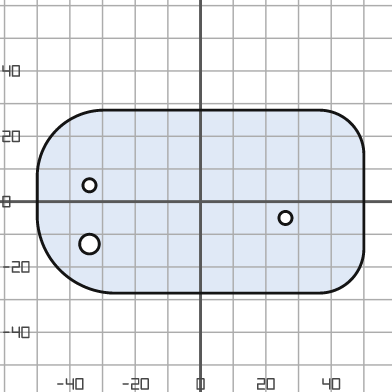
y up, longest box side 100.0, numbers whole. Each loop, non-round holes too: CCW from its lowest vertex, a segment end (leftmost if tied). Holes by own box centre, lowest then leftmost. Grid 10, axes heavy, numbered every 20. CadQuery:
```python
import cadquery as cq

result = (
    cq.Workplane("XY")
    .moveTo(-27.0, -28.0)
    .lineTo(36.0, -28.0)
    .threePointArc((46.0, -24.0), (50.0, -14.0))
    .lineTo(50.0, 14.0)
    .threePointArc((46.0, 24.0), (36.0, 28.0))
    .lineTo(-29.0, 28.0)
    .threePointArc((-44.0, 22.0), (-50.0, 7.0))
    .lineTo(-50.0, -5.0)
    .threePointArc((-43.0, -21.0), (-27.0, -28.0))
    .close()
    .moveTo(-34.0, -13.0)
    .circle(3.0)
    .moveTo(26.0, -5.0)
    .circle(2.0)
    .moveTo(-34.0, 5.0)
    .circle(2.0)
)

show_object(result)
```